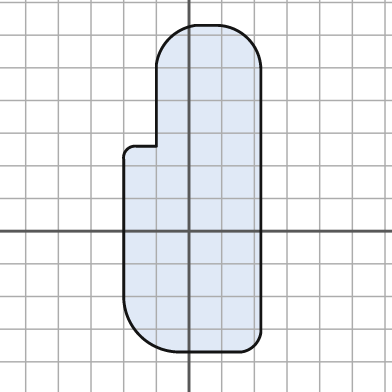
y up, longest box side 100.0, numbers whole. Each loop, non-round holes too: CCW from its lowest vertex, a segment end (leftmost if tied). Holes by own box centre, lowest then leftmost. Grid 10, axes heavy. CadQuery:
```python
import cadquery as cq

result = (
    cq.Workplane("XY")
    .moveTo(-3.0, -37.0)
    .lineTo(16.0, -37.0)
    .threePointArc((20.0, -35.0), (22.0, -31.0))
    .lineTo(22.0, 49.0)
    .threePointArc((18.0, 59.0), (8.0, 63.0))
    .lineTo(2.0, 63.0)
    .threePointArc((-6.0, 59.0), (-10.0, 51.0))
    .lineTo(-10.0, 26.0)
    .lineTo(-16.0, 26.0)
    .threePointArc((-19.0, 25.0), (-20.0, 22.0))
    .lineTo(-20.0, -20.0)
    .threePointArc((-15.0, -32.0), (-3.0, -37.0))
    .close()
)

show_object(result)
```